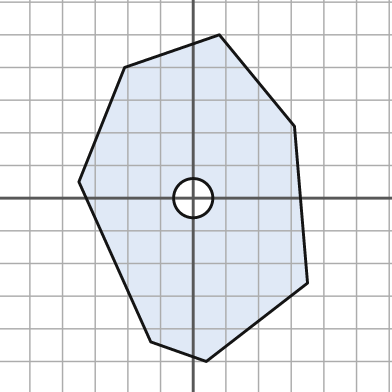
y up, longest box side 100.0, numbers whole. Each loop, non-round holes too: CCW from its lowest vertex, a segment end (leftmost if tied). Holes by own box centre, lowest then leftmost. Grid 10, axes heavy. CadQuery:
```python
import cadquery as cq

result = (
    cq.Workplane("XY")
    .moveTo(4.0, -50.0)
    .lineTo(35.0, -26.0)
    .lineTo(31.0, 22.0)
    .lineTo(8.0, 50.0)
    .lineTo(-21.0, 40.0)
    .lineTo(-35.0, 5.0)
    .lineTo(-13.0, -44.0)
    .close()
    .moveTo(0.0, 0.0)
    .circle(6.0)
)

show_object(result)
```